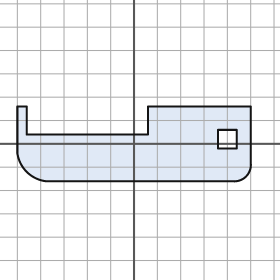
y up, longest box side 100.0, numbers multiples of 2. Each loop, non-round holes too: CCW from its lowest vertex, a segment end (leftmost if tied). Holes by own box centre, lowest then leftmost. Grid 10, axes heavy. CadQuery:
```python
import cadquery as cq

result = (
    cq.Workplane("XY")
    .moveTo(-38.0, -16.0)
    .lineTo(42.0, -16.0)
    .threePointArc((48.0, -14.0), (50.0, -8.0))
    .lineTo(50.0, 16.0)
    .lineTo(6.0, 16.0)
    .lineTo(6.0, 4.0)
    .lineTo(-46.0, 4.0)
    .lineTo(-46.0, 16.0)
    .lineTo(-50.0, 16.0)
    .lineTo(-50.0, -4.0)
    .threePointArc((-46.0, -12.0), (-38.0, -16.0))
    .close()
    .moveTo(36.0, -2.0)
    .lineTo(44.0, -2.0)
    .lineTo(44.0, 6.0)
    .lineTo(36.0, 6.0)
    .close()
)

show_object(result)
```